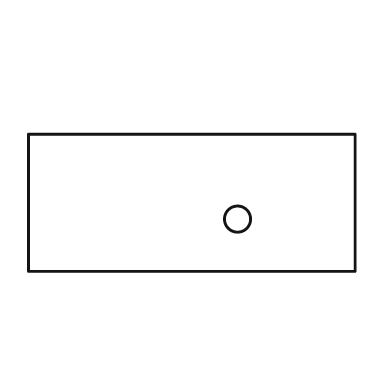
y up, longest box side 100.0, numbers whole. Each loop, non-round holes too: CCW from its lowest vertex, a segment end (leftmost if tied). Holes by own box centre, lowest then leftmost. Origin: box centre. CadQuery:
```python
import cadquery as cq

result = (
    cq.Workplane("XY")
    .moveTo(-50.0, -21.0)
    .lineTo(50.0, -21.0)
    .lineTo(50.0, 21.0)
    .lineTo(-50.0, 21.0)
    .close()
    .moveTo(14.0, -5.0)
    .circle(4.0)
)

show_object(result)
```